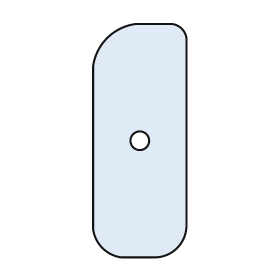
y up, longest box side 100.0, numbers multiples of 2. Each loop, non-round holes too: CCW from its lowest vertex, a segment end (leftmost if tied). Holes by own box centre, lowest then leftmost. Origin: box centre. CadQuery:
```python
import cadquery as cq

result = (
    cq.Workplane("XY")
    .moveTo(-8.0, -50.0)
    .lineTo(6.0, -50.0)
    .threePointArc((16.0, -46.0), (20.0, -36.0))
    .lineTo(20.0, 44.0)
    .threePointArc((18.0, 48.0), (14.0, 50.0))
    .lineTo(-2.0, 50.0)
    .threePointArc((-14.0, 44.0), (-20.0, 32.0))
    .lineTo(-20.0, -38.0)
    .threePointArc((-16.0, -46.0), (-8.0, -50.0))
    .close()
    .moveTo(0.0, 0.0)
    .circle(4.0)
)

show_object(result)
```